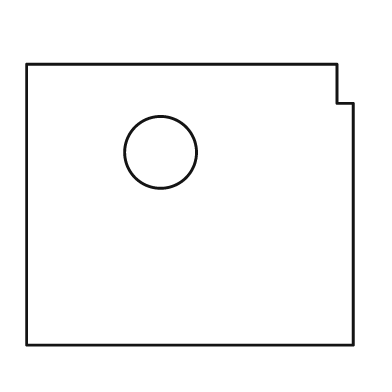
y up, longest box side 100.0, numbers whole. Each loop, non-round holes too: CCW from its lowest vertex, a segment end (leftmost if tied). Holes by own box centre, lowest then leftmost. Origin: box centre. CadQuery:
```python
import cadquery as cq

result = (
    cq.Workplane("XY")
    .moveTo(-50.0, -43.0)
    .lineTo(50.0, -43.0)
    .lineTo(50.0, 31.0)
    .lineTo(45.0, 31.0)
    .lineTo(45.0, 43.0)
    .lineTo(-50.0, 43.0)
    .close()
    .moveTo(-9.0, 16.0)
    .circle(11.0)
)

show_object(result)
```